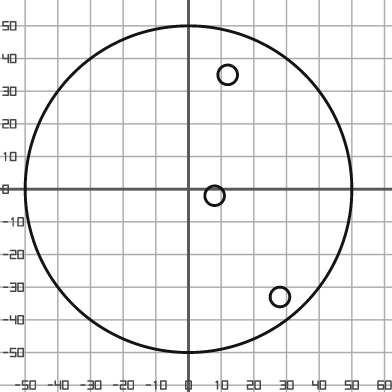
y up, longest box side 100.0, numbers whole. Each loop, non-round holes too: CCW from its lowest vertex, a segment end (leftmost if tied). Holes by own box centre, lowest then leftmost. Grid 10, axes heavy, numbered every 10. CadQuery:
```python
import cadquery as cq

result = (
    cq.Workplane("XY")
    .moveTo(0.0, 0.0)
    .circle(50.0)
    .moveTo(28.0, -33.0)
    .circle(3.0)
    .moveTo(8.0, -2.0)
    .circle(3.0)
    .moveTo(12.0, 35.0)
    .circle(3.0)
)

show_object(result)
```